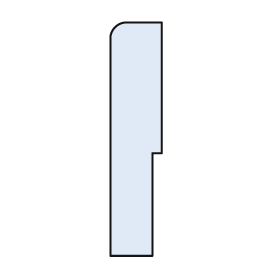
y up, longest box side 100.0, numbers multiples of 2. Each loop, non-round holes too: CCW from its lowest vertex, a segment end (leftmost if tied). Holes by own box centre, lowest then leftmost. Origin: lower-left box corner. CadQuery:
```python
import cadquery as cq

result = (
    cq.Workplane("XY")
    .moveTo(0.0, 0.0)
    .lineTo(18.0, 0.0)
    .lineTo(18.0, 44.0)
    .lineTo(22.0, 44.0)
    .lineTo(22.0, 100.0)
    .lineTo(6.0, 100.0)
    .threePointArc((2.0, 98.0), (0.0, 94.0))
    .close()
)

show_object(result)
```